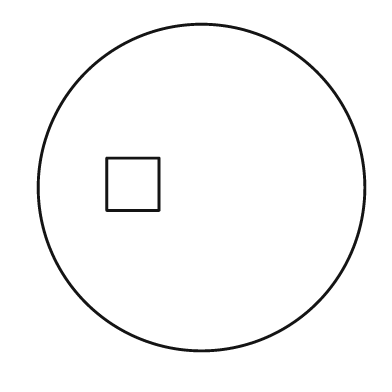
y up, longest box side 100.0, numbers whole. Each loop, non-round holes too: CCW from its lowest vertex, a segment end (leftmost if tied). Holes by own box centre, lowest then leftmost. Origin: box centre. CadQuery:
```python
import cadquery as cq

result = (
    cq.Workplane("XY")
    .moveTo(0.0, 0.0)
    .circle(50.0)
    .moveTo(-29.0, -7.0)
    .lineTo(-13.0, -7.0)
    .lineTo(-13.0, 9.0)
    .lineTo(-29.0, 9.0)
    .close()
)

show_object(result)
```